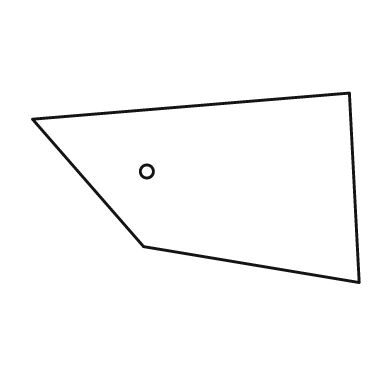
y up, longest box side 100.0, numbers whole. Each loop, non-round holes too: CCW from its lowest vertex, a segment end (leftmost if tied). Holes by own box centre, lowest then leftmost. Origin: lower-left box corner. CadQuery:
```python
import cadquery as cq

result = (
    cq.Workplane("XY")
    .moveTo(100.0, 0.0)
    .lineTo(97.0, 58.0)
    .lineTo(0.0, 50.0)
    .lineTo(34.0, 11.0)
    .close()
    .moveTo(35.0, 34.0)
    .circle(2.0)
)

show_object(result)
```